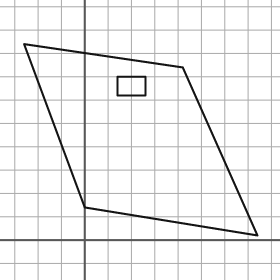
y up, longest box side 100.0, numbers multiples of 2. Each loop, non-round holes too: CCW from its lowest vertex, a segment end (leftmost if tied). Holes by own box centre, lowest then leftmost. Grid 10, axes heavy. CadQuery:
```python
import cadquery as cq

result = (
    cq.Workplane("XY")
    .moveTo(74.0, 2.0)
    .lineTo(42.0, 74.0)
    .lineTo(-26.0, 84.0)
    .lineTo(0.0, 14.0)
    .close()
    .moveTo(14.0, 62.0)
    .lineTo(26.0, 62.0)
    .lineTo(26.0, 70.0)
    .lineTo(14.0, 70.0)
    .close()
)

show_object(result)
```